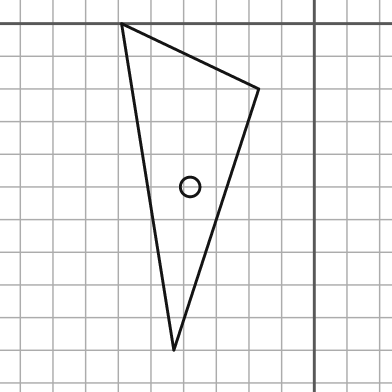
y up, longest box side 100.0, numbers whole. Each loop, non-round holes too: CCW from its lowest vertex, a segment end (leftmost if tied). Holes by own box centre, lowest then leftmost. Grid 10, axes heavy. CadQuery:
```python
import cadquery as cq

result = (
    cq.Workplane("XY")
    .moveTo(-43.0, -100.0)
    .lineTo(-17.0, -20.0)
    .lineTo(-59.0, 0.0)
    .close()
    .moveTo(-38.0, -50.0)
    .circle(3.0)
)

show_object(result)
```